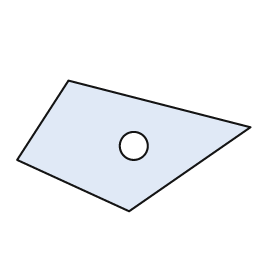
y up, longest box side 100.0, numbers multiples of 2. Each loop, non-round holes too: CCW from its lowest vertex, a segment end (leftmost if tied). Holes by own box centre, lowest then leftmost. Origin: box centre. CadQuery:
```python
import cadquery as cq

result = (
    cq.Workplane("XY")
    .moveTo(-2.0, -28.0)
    .lineTo(50.0, 8.0)
    .lineTo(-28.0, 28.0)
    .lineTo(-50.0, -6.0)
    .close()
    .moveTo(0.0, 0.0)
    .circle(6.0)
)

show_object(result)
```